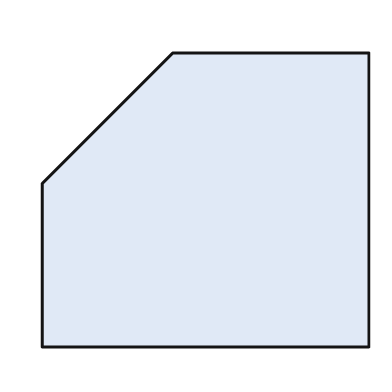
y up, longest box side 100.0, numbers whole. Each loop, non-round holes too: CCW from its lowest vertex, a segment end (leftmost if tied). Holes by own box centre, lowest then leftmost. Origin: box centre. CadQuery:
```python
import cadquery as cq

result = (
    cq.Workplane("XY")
    .moveTo(-50.0, -45.0)
    .lineTo(50.0, -45.0)
    .lineTo(50.0, 45.0)
    .lineTo(-10.0, 45.0)
    .lineTo(-50.0, 5.0)
    .close()
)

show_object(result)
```